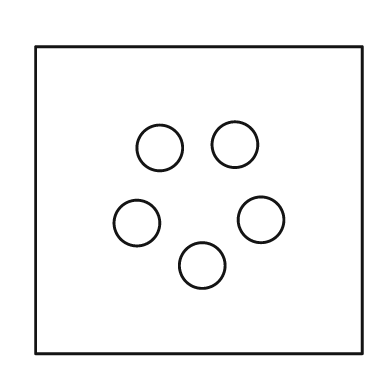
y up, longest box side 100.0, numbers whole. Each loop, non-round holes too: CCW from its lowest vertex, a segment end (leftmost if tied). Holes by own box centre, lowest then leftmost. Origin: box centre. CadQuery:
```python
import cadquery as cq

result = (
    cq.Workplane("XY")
    .moveTo(-50.0, -47.0)
    .lineTo(50.0, -47.0)
    .lineTo(50.0, 47.0)
    .lineTo(-50.0, 47.0)
    .close()
    .moveTo(1.0, -20.0)
    .circle(7.0)
    .moveTo(-19.0, -7.0)
    .circle(7.0)
    .moveTo(19.0, -6.0)
    .circle(7.0)
    .moveTo(-12.0, 16.0)
    .circle(7.0)
    .moveTo(11.0, 17.0)
    .circle(7.0)
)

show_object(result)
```